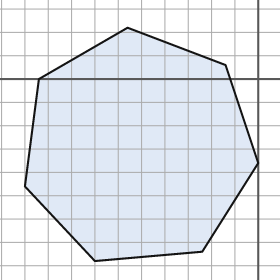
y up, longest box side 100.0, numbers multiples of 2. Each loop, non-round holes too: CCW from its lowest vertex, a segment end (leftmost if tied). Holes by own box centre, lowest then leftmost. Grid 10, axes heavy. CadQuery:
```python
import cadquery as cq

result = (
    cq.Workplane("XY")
    .moveTo(-70.0, -78.0)
    .lineTo(-24.0, -74.0)
    .lineTo(0.0, -36.0)
    .lineTo(-14.0, 6.0)
    .lineTo(-56.0, 22.0)
    .lineTo(-94.0, 0.0)
    .lineTo(-100.0, -46.0)
    .close()
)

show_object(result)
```